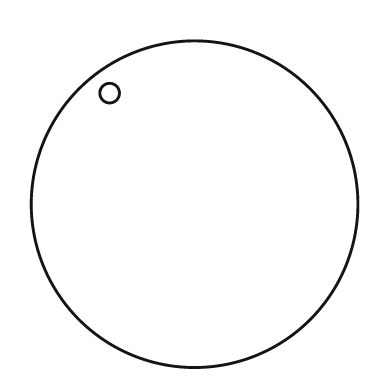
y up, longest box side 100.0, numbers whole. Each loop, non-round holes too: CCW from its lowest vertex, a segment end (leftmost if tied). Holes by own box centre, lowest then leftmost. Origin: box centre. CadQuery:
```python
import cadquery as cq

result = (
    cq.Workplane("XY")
    .moveTo(0.0, 0.0)
    .circle(50.0)
    .moveTo(-26.0, 34.0)
    .circle(3.0)
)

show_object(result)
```